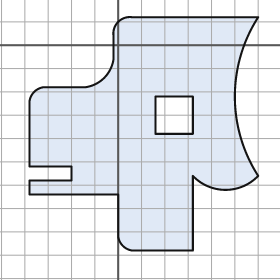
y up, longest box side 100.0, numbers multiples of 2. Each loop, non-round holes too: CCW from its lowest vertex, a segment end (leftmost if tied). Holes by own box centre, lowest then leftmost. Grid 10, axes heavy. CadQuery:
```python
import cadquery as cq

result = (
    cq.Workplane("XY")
    .moveTo(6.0, -88.0)
    .lineTo(32.0, -88.0)
    .lineTo(32.0, -56.0)
    .threePointArc((46.0, -62.0), (60.0, -56.0))
    .threePointArc((50.0, -22.0), (60.0, 12.0))
    .lineTo(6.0, 12.0)
    .threePointArc((0.0, 10.0), (-2.0, 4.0))
    .lineTo(-2.0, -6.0)
    .threePointArc((-6.0, -14.0), (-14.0, -18.0))
    .lineTo(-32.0, -18.0)
    .threePointArc((-36.0, -20.0), (-38.0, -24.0))
    .lineTo(-38.0, -52.0)
    .lineTo(-20.0, -52.0)
    .lineTo(-20.0, -58.0)
    .lineTo(-38.0, -58.0)
    .lineTo(-38.0, -64.0)
    .lineTo(0.0, -64.0)
    .lineTo(0.0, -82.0)
    .threePointArc((2.0, -86.0), (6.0, -88.0))
    .close()
    .moveTo(16.0, -38.0)
    .lineTo(32.0, -38.0)
    .lineTo(32.0, -22.0)
    .lineTo(16.0, -22.0)
    .close()
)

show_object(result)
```